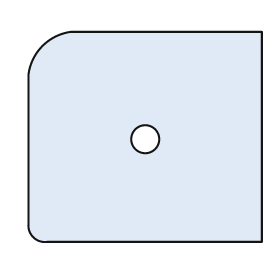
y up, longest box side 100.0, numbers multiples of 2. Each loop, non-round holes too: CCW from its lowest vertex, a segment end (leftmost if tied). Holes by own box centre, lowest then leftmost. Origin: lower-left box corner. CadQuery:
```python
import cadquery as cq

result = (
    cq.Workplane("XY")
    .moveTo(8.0, 0.0)
    .lineTo(100.0, 0.0)
    .lineTo(100.0, 90.0)
    .lineTo(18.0, 90.0)
    .threePointArc((6.0, 84.0), (0.0, 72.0))
    .lineTo(0.0, 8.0)
    .threePointArc((2.0, 2.0), (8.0, 0.0))
    .close()
    .moveTo(50.0, 44.0)
    .circle(6.0)
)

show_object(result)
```